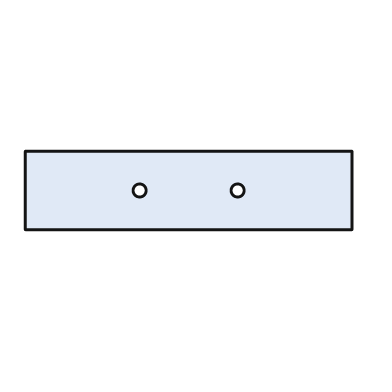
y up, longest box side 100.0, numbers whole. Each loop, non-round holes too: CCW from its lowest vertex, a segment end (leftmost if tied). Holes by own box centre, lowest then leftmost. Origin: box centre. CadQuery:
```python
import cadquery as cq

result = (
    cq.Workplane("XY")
    .moveTo(-50.0, -12.0)
    .lineTo(50.0, -12.0)
    .lineTo(50.0, 12.0)
    .lineTo(-50.0, 12.0)
    .close()
    .moveTo(-15.0, 0.0)
    .circle(2.0)
    .moveTo(15.0, 0.0)
    .circle(2.0)
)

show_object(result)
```